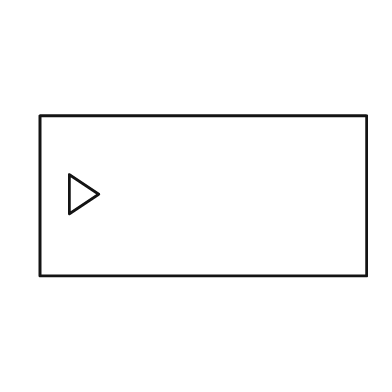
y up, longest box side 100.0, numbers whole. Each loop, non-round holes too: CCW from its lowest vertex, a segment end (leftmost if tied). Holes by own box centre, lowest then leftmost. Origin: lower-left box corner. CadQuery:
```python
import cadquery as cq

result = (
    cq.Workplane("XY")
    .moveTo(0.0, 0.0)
    .lineTo(100.0, 0.0)
    .lineTo(100.0, 49.0)
    .lineTo(0.0, 49.0)
    .close()
    .moveTo(9.0, 19.0)
    .lineTo(18.0, 25.0)
    .lineTo(9.0, 31.0)
    .close()
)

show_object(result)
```